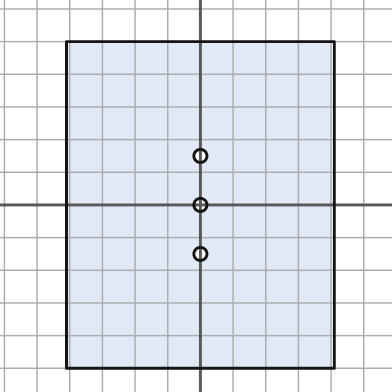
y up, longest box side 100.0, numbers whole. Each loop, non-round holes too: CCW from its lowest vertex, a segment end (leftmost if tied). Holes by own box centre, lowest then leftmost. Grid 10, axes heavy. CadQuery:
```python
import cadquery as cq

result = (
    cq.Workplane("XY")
    .moveTo(-41.0, -50.0)
    .lineTo(41.0, -50.0)
    .lineTo(41.0, 50.0)
    .lineTo(-41.0, 50.0)
    .close()
    .moveTo(0.0, -15.0)
    .circle(2.0)
    .moveTo(0.0, 0.0)
    .circle(2.0)
    .moveTo(0.0, 15.0)
    .circle(2.0)
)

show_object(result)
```